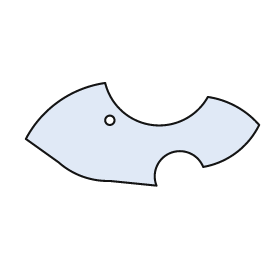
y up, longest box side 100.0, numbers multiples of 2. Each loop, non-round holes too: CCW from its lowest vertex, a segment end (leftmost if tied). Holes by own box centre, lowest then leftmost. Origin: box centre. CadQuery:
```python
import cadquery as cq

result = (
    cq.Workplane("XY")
    .moveTo(6.0, -22.0)
    .threePointArc((12.0, -8.0), (26.0, -14.0))
    .threePointArc((40.0, -8.0), (50.0, 4.0))
    .threePointArc((40.0, 12.0), (28.0, 16.0))
    .threePointArc((4.0, 4.0), (-16.0, 22.0))
    .threePointArc((-36.0, 14.0), (-50.0, -2.0))
    .lineTo(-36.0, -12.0)
    .threePointArc((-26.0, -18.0), (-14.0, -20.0))
    .close()
    .moveTo(-14.0, 6.0)
    .circle(2.0)
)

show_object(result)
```